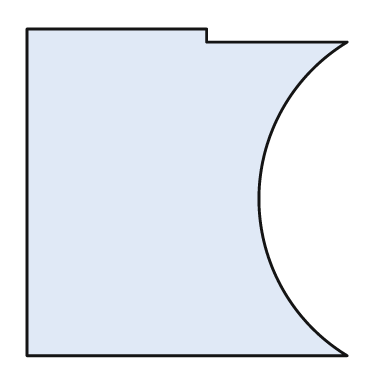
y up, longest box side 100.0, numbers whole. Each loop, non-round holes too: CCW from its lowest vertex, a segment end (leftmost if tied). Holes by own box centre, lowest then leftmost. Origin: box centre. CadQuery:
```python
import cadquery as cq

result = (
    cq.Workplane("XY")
    .moveTo(-49.0, -50.0)
    .lineTo(49.0, -50.0)
    .threePointArc((22.0, -2.0), (49.0, 46.0))
    .lineTo(6.0, 46.0)
    .lineTo(6.0, 50.0)
    .lineTo(-49.0, 50.0)
    .close()
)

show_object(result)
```